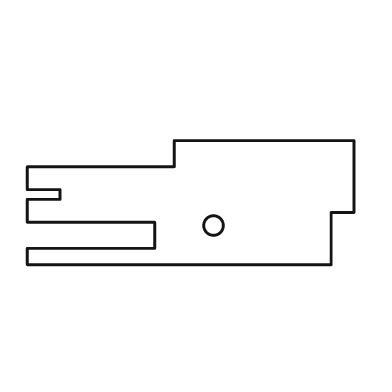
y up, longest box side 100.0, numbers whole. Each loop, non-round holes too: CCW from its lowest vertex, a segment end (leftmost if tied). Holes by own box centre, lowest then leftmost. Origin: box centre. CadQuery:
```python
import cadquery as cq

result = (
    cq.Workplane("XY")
    .moveTo(-50.0, -19.0)
    .lineTo(43.0, -19.0)
    .lineTo(43.0, -3.0)
    .lineTo(50.0, -3.0)
    .lineTo(50.0, 19.0)
    .lineTo(-5.0, 19.0)
    .lineTo(-5.0, 11.0)
    .lineTo(-50.0, 11.0)
    .lineTo(-50.0, 4.0)
    .lineTo(-40.0, 4.0)
    .lineTo(-40.0, 1.0)
    .lineTo(-50.0, 1.0)
    .lineTo(-50.0, -6.0)
    .lineTo(-11.0, -6.0)
    .lineTo(-11.0, -14.0)
    .lineTo(-50.0, -14.0)
    .close()
    .moveTo(7.0, -7.0)
    .circle(3.0)
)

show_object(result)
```